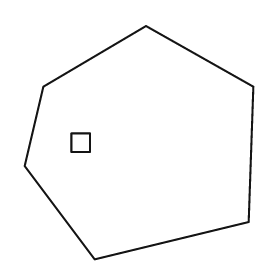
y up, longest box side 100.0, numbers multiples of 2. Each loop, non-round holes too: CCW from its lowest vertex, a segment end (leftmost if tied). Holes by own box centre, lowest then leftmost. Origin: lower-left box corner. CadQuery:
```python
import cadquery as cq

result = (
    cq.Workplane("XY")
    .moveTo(30.0, 0.0)
    .lineTo(96.0, 16.0)
    .lineTo(98.0, 74.0)
    .lineTo(52.0, 100.0)
    .lineTo(8.0, 74.0)
    .lineTo(0.0, 40.0)
    .close()
    .moveTo(20.0, 46.0)
    .lineTo(28.0, 46.0)
    .lineTo(28.0, 54.0)
    .lineTo(20.0, 54.0)
    .close()
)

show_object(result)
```